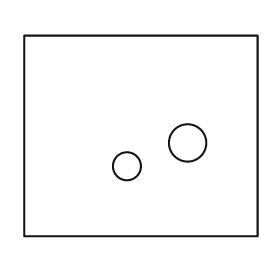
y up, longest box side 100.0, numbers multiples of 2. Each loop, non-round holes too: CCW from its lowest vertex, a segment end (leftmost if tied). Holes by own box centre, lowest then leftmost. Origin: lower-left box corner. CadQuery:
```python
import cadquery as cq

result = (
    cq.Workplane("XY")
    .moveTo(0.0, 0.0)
    .lineTo(100.0, 0.0)
    .lineTo(100.0, 86.0)
    .lineTo(0.0, 86.0)
    .close()
    .moveTo(44.0, 30.0)
    .circle(6.0)
    .moveTo(70.0, 40.0)
    .circle(8.0)
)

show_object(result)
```